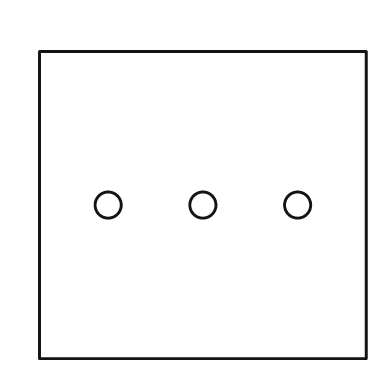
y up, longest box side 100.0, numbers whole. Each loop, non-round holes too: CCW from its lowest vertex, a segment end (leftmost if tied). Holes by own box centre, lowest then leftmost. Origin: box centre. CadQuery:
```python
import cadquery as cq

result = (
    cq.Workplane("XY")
    .moveTo(-50.0, -47.0)
    .lineTo(50.0, -47.0)
    .lineTo(50.0, 47.0)
    .lineTo(-50.0, 47.0)
    .close()
    .moveTo(-29.0, 0.0)
    .circle(4.0)
    .moveTo(0.0, 0.0)
    .circle(4.0)
    .moveTo(29.0, 0.0)
    .circle(4.0)
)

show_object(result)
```